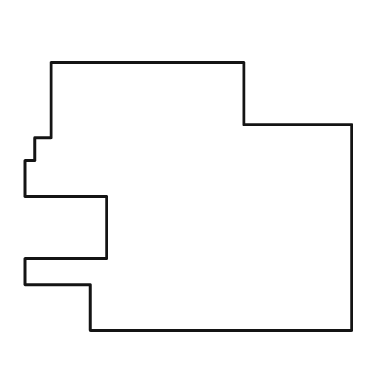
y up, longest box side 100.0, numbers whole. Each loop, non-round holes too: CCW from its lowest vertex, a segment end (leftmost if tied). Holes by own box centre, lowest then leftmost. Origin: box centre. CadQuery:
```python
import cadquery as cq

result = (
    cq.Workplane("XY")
    .moveTo(-30.0, -41.0)
    .lineTo(50.0, -41.0)
    .lineTo(50.0, 22.0)
    .lineTo(17.0, 22.0)
    .lineTo(17.0, 41.0)
    .lineTo(-42.0, 41.0)
    .lineTo(-42.0, 18.0)
    .lineTo(-47.0, 18.0)
    .lineTo(-47.0, 11.0)
    .lineTo(-50.0, 11.0)
    .lineTo(-50.0, 0.0)
    .lineTo(-25.0, 0.0)
    .lineTo(-25.0, -19.0)
    .lineTo(-50.0, -19.0)
    .lineTo(-50.0, -27.0)
    .lineTo(-30.0, -27.0)
    .close()
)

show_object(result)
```